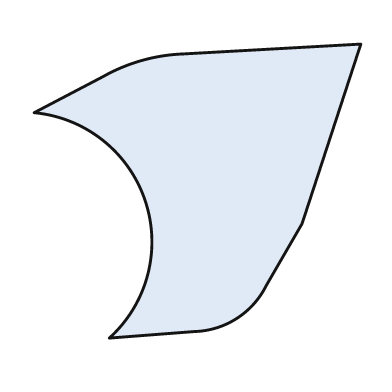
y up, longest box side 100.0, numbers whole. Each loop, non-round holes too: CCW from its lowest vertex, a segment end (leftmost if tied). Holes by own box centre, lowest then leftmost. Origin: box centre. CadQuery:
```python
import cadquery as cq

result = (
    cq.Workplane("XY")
    .moveTo(-27.0, -45.0)
    .lineTo(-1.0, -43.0)
    .threePointArc((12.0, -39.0), (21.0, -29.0))
    .lineTo(32.0, -10.0)
    .lineTo(50.0, 45.0)
    .lineTo(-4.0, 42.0)
    .threePointArc((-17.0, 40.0), (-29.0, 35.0))
    .lineTo(-50.0, 24.0)
    .threePointArc((-16.0, -3.0), (-27.0, -45.0))
    .close()
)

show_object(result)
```